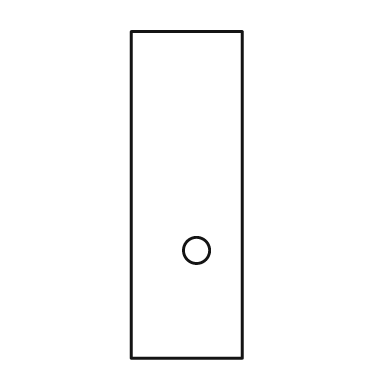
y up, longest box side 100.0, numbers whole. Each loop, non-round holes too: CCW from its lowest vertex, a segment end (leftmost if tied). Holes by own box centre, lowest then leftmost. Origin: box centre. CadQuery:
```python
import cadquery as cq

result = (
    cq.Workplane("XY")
    .moveTo(-17.0, -50.0)
    .lineTo(17.0, -50.0)
    .lineTo(17.0, 50.0)
    .lineTo(-17.0, 50.0)
    .close()
    .moveTo(3.0, -17.0)
    .circle(4.0)
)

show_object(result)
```